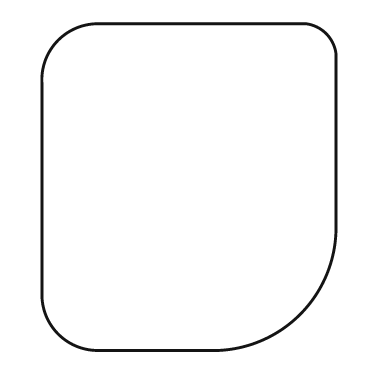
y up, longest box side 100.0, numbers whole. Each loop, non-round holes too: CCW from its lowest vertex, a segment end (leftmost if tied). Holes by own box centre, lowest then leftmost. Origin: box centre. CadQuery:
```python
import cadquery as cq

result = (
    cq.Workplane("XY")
    .moveTo(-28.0, -50.0)
    .lineTo(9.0, -50.0)
    .threePointArc((34.0, -39.0), (45.0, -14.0))
    .lineTo(45.0, 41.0)
    .threePointArc((42.0, 47.0), (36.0, 50.0))
    .lineTo(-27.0, 50.0)
    .threePointArc((-40.0, 45.0), (-45.0, 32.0))
    .lineTo(-45.0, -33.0)
    .threePointArc((-40.0, -45.0), (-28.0, -50.0))
    .close()
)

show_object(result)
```